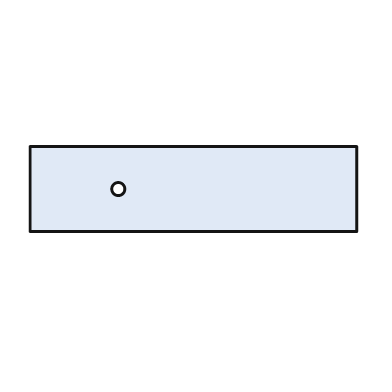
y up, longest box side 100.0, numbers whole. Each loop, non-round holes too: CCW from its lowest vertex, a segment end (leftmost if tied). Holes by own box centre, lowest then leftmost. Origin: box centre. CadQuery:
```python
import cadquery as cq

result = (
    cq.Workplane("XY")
    .moveTo(-50.0, -13.0)
    .lineTo(50.0, -13.0)
    .lineTo(50.0, 13.0)
    .lineTo(-50.0, 13.0)
    .close()
    .moveTo(-23.0, 0.0)
    .circle(2.0)
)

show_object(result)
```